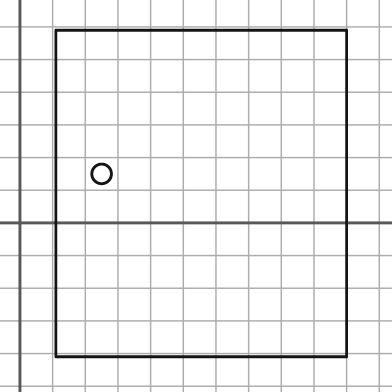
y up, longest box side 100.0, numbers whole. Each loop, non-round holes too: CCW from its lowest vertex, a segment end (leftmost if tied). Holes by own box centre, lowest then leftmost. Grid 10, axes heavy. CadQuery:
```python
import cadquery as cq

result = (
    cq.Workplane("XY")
    .moveTo(11.0, -41.0)
    .lineTo(100.0, -41.0)
    .lineTo(100.0, 59.0)
    .lineTo(11.0, 59.0)
    .close()
    .moveTo(25.0, 15.0)
    .circle(3.0)
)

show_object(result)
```